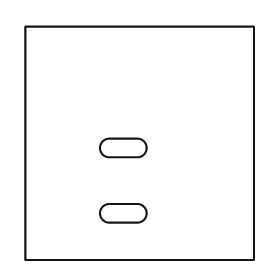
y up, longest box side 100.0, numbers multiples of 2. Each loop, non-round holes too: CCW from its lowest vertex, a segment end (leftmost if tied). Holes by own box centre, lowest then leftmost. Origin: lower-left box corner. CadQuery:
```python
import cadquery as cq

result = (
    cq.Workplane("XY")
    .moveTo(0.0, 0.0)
    .lineTo(98.0, 0.0)
    .lineTo(98.0, 100.0)
    .lineTo(0.0, 100.0)
    .close()
    .moveTo(36.0, 16.0)
    .lineTo(48.0, 16.0)
    .threePointArc((52.0, 20.0), (48.0, 24.0))
    .lineTo(36.0, 24.0)
    .threePointArc((32.0, 20.0), (36.0, 16.0))
    .close()
    .moveTo(36.0, 44.0)
    .lineTo(48.0, 44.0)
    .threePointArc((52.0, 48.0), (48.0, 52.0))
    .lineTo(36.0, 52.0)
    .threePointArc((32.0, 48.0), (36.0, 44.0))
    .close()
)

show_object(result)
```